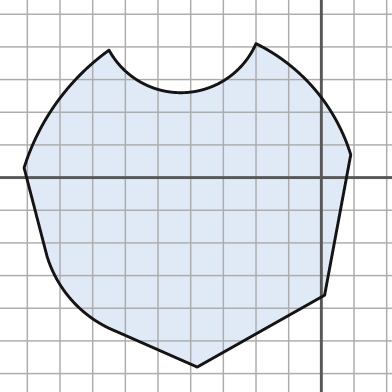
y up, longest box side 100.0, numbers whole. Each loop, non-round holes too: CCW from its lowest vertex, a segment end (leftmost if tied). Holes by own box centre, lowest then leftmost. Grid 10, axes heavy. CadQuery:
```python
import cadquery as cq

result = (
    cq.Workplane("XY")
    .moveTo(-38.0, -58.0)
    .lineTo(1.0, -36.0)
    .lineTo(9.0, 7.0)
    .threePointArc((-2.0, 27.0), (-20.0, 41.0))
    .threePointArc((-42.0, 26.0), (-65.0, 39.0))
    .threePointArc((-81.0, 23.0), (-91.0, 3.0))
    .lineTo(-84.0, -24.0)
    .threePointArc((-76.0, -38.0), (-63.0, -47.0))
    .close()
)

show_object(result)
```